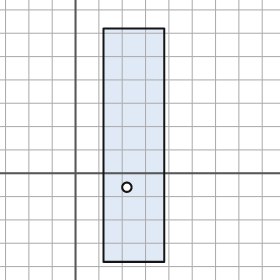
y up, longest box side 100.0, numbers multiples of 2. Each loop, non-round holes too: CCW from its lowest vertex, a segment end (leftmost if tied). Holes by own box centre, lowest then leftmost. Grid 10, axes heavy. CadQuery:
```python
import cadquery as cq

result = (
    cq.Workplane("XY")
    .moveTo(12.0, -38.0)
    .lineTo(38.0, -38.0)
    .lineTo(38.0, 62.0)
    .lineTo(12.0, 62.0)
    .close()
    .moveTo(22.0, -6.0)
    .circle(2.0)
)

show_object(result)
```